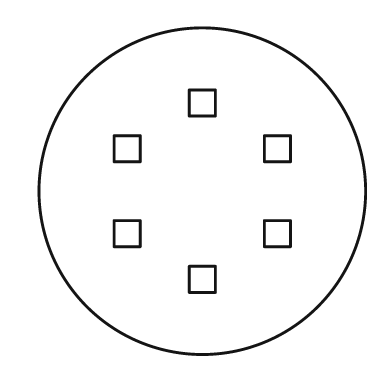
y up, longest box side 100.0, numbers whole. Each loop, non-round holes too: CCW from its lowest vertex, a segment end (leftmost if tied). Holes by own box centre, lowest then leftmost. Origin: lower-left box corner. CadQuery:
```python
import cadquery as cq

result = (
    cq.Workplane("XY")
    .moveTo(50.0, 50.0)
    .circle(50.0)
    .moveTo(46.0, 19.0)
    .lineTo(54.0, 19.0)
    .lineTo(54.0, 27.0)
    .lineTo(46.0, 27.0)
    .close()
    .moveTo(23.0, 33.0)
    .lineTo(31.0, 33.0)
    .lineTo(31.0, 41.0)
    .lineTo(23.0, 41.0)
    .close()
    .moveTo(69.0, 33.0)
    .lineTo(77.0, 33.0)
    .lineTo(77.0, 41.0)
    .lineTo(69.0, 41.0)
    .close()
    .moveTo(23.0, 59.0)
    .lineTo(31.0, 59.0)
    .lineTo(31.0, 67.0)
    .lineTo(23.0, 67.0)
    .close()
    .moveTo(69.0, 59.0)
    .lineTo(77.0, 59.0)
    .lineTo(77.0, 67.0)
    .lineTo(69.0, 67.0)
    .close()
    .moveTo(46.0, 73.0)
    .lineTo(54.0, 73.0)
    .lineTo(54.0, 81.0)
    .lineTo(46.0, 81.0)
    .close()
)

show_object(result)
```